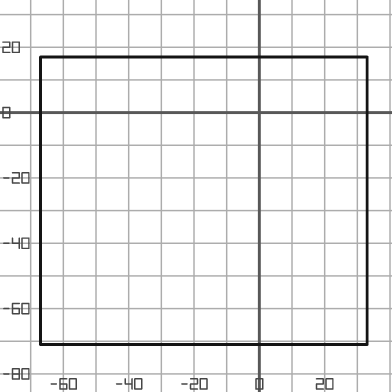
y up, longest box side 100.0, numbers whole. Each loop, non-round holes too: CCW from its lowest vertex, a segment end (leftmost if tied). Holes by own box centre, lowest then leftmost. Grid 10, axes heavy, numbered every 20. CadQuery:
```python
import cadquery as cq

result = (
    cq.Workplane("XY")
    .moveTo(-67.0, -71.0)
    .lineTo(33.0, -71.0)
    .lineTo(33.0, 17.0)
    .lineTo(-67.0, 17.0)
    .close()
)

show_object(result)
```